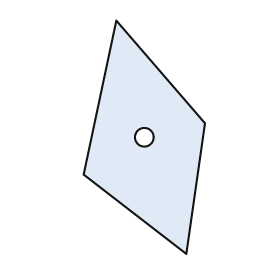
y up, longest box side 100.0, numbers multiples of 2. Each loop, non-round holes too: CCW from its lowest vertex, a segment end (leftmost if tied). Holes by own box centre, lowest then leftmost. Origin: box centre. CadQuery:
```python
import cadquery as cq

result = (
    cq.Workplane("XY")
    .moveTo(18.0, -50.0)
    .lineTo(26.0, 6.0)
    .lineTo(-12.0, 50.0)
    .lineTo(-26.0, -16.0)
    .close()
    .moveTo(0.0, 0.0)
    .circle(4.0)
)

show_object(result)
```